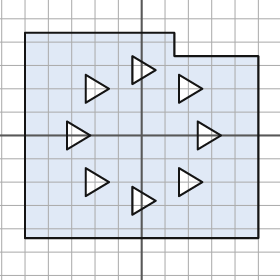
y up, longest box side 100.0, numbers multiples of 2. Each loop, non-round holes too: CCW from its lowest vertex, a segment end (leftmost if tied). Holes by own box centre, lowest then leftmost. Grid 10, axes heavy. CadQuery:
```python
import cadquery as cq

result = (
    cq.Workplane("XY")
    .moveTo(-50.0, -44.0)
    .lineTo(50.0, -44.0)
    .lineTo(50.0, 34.0)
    .lineTo(14.0, 34.0)
    .lineTo(14.0, 44.0)
    .lineTo(-50.0, 44.0)
    .close()
    .moveTo(-4.0, -34.0)
    .lineTo(6.0, -28.0)
    .lineTo(-4.0, -22.0)
    .close()
    .moveTo(-24.0, -26.0)
    .lineTo(-14.0, -20.0)
    .lineTo(-24.0, -14.0)
    .close()
    .moveTo(16.0, -26.0)
    .lineTo(26.0, -20.0)
    .lineTo(16.0, -14.0)
    .close()
    .moveTo(-32.0, -6.0)
    .lineTo(-22.0, 0.0)
    .lineTo(-32.0, 6.0)
    .close()
    .moveTo(24.0, -6.0)
    .lineTo(34.0, 0.0)
    .lineTo(24.0, 6.0)
    .close()
    .moveTo(-24.0, 14.0)
    .lineTo(-14.0, 20.0)
    .lineTo(-24.0, 26.0)
    .close()
    .moveTo(16.0, 14.0)
    .lineTo(26.0, 20.0)
    .lineTo(16.0, 26.0)
    .close()
    .moveTo(-4.0, 22.0)
    .lineTo(6.0, 28.0)
    .lineTo(-4.0, 34.0)
    .close()
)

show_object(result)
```